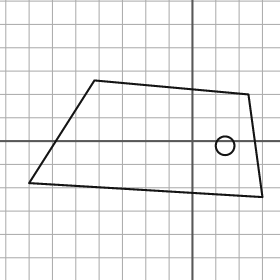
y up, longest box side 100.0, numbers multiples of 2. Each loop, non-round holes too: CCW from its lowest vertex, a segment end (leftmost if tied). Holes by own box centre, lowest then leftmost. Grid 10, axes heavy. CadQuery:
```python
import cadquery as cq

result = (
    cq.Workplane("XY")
    .moveTo(30.0, -24.0)
    .lineTo(24.0, 20.0)
    .lineTo(-42.0, 26.0)
    .lineTo(-70.0, -18.0)
    .close()
    .moveTo(14.0, -2.0)
    .circle(4.0)
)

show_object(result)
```